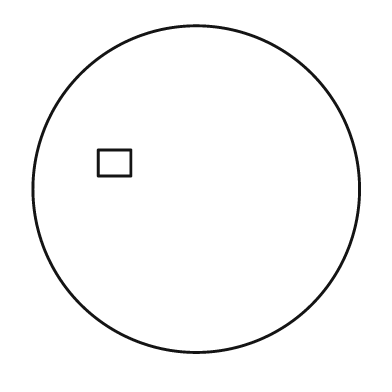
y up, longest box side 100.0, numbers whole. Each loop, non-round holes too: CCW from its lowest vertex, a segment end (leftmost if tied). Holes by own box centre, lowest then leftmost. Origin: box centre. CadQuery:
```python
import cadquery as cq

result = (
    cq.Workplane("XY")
    .moveTo(0.0, 0.0)
    .circle(50.0)
    .moveTo(-30.0, 4.0)
    .lineTo(-20.0, 4.0)
    .lineTo(-20.0, 12.0)
    .lineTo(-30.0, 12.0)
    .close()
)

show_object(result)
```